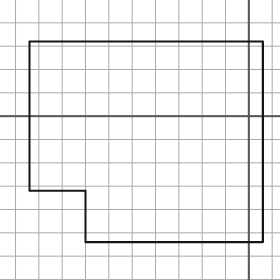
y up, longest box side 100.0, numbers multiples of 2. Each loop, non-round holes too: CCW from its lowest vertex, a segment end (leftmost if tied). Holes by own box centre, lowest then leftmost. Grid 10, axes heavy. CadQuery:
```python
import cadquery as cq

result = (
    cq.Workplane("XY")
    .moveTo(-70.0, -54.0)
    .lineTo(6.0, -54.0)
    .lineTo(6.0, 32.0)
    .lineTo(-94.0, 32.0)
    .lineTo(-94.0, -32.0)
    .lineTo(-70.0, -32.0)
    .close()
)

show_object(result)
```